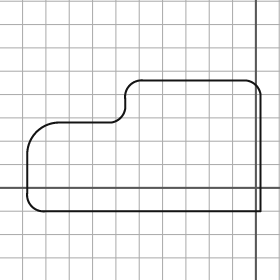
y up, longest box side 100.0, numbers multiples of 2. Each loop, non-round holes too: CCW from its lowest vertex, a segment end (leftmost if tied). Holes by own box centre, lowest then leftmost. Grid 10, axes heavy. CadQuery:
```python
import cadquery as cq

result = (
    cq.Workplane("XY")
    .moveTo(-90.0, -10.0)
    .lineTo(2.0, -10.0)
    .lineTo(2.0, 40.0)
    .threePointArc((0.0, 44.0), (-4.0, 46.0))
    .lineTo(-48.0, 46.0)
    .threePointArc((-54.0, 44.0), (-56.0, 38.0))
    .lineTo(-56.0, 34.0)
    .threePointArc((-58.0, 30.0), (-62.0, 28.0))
    .lineTo(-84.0, 28.0)
    .threePointArc((-94.0, 24.0), (-98.0, 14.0))
    .lineTo(-98.0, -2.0)
    .threePointArc((-96.0, -8.0), (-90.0, -10.0))
    .close()
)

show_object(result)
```